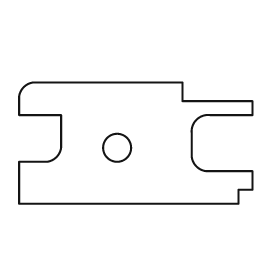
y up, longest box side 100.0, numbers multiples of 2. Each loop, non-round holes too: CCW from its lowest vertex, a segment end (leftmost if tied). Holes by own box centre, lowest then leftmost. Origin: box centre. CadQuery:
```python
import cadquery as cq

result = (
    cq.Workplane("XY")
    .moveTo(-50.0, -26.0)
    .lineTo(44.0, -26.0)
    .lineTo(44.0, -20.0)
    .lineTo(50.0, -20.0)
    .lineTo(50.0, -12.0)
    .lineTo(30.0, -12.0)
    .threePointArc((26.0, -10.0), (24.0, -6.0))
    .lineTo(24.0, 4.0)
    .threePointArc((26.0, 10.0), (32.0, 12.0))
    .lineTo(50.0, 12.0)
    .lineTo(50.0, 18.0)
    .lineTo(20.0, 18.0)
    .lineTo(20.0, 26.0)
    .lineTo(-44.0, 26.0)
    .threePointArc((-48.0, 24.0), (-50.0, 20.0))
    .lineTo(-50.0, 12.0)
    .lineTo(-32.0, 12.0)
    .lineTo(-32.0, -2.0)
    .threePointArc((-34.0, -6.0), (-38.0, -8.0))
    .lineTo(-50.0, -8.0)
    .close()
    .moveTo(-8.0, -2.0)
    .circle(6.0)
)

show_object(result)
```